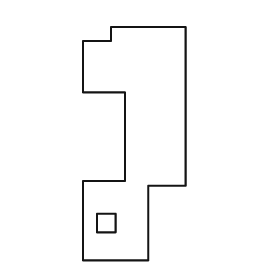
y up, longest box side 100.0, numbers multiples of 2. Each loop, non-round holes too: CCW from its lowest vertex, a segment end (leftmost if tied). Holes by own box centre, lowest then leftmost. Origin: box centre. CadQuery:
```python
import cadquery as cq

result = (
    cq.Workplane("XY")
    .moveTo(-22.0, -50.0)
    .lineTo(6.0, -50.0)
    .lineTo(6.0, -18.0)
    .lineTo(22.0, -18.0)
    .lineTo(22.0, 50.0)
    .lineTo(-10.0, 50.0)
    .lineTo(-10.0, 44.0)
    .lineTo(-22.0, 44.0)
    .lineTo(-22.0, 22.0)
    .lineTo(-4.0, 22.0)
    .lineTo(-4.0, -16.0)
    .lineTo(-22.0, -16.0)
    .close()
    .moveTo(-16.0, -38.0)
    .lineTo(-8.0, -38.0)
    .lineTo(-8.0, -30.0)
    .lineTo(-16.0, -30.0)
    .close()
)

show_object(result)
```